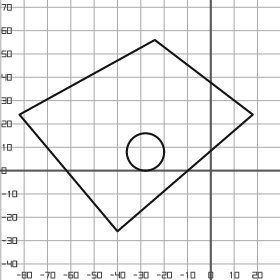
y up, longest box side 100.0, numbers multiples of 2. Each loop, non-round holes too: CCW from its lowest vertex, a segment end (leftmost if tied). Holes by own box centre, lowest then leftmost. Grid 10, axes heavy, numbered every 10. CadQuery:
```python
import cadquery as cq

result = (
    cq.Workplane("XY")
    .moveTo(-40.0, -26.0)
    .lineTo(18.0, 24.0)
    .lineTo(-24.0, 56.0)
    .lineTo(-82.0, 24.0)
    .close()
    .moveTo(-28.0, 8.0)
    .circle(8.0)
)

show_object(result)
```